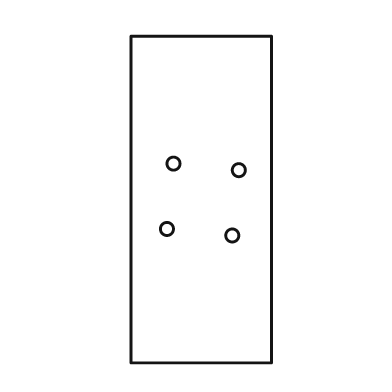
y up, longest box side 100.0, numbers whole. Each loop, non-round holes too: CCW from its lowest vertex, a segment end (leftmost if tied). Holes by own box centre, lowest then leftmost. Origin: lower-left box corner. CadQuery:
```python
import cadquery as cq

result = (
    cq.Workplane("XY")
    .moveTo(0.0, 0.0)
    .lineTo(43.0, 0.0)
    .lineTo(43.0, 100.0)
    .lineTo(0.0, 100.0)
    .close()
    .moveTo(31.0, 39.0)
    .circle(2.0)
    .moveTo(11.0, 41.0)
    .circle(2.0)
    .moveTo(33.0, 59.0)
    .circle(2.0)
    .moveTo(13.0, 61.0)
    .circle(2.0)
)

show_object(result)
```